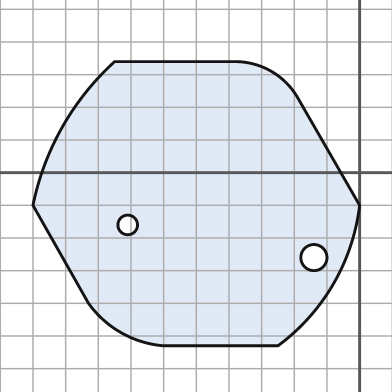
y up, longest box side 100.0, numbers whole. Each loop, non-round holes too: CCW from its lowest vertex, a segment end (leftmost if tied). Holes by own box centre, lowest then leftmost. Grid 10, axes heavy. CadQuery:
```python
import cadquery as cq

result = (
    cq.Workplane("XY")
    .moveTo(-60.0, -53.0)
    .lineTo(-25.0, -53.0)
    .threePointArc((-8.0, -34.0), (0.0, -10.0))
    .lineTo(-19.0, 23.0)
    .threePointArc((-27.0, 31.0), (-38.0, 34.0))
    .lineTo(-75.0, 34.0)
    .threePointArc((-91.0, 14.0), (-100.0, -10.0))
    .lineTo(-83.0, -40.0)
    .threePointArc((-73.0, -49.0), (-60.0, -53.0))
    .close()
    .moveTo(-14.0, -26.0)
    .circle(4.0)
    .moveTo(-71.0, -16.0)
    .circle(3.0)
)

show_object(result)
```